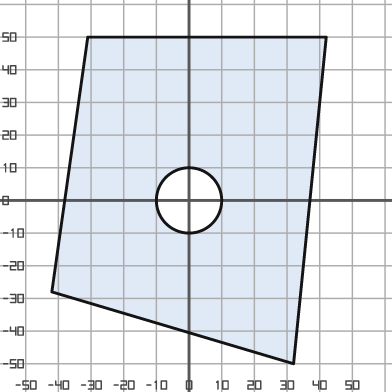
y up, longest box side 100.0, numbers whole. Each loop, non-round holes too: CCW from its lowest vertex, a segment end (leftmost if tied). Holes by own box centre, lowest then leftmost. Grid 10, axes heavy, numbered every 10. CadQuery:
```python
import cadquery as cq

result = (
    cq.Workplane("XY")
    .moveTo(32.0, -50.0)
    .lineTo(42.0, 50.0)
    .lineTo(-31.0, 50.0)
    .lineTo(-42.0, -28.0)
    .close()
    .moveTo(0.0, 0.0)
    .circle(10.0)
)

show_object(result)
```